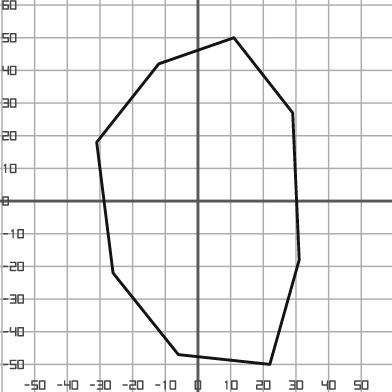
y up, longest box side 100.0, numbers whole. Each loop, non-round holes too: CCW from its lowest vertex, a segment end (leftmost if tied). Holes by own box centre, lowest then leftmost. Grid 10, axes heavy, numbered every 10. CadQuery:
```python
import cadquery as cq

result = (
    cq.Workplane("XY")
    .moveTo(22.0, -50.0)
    .lineTo(31.0, -18.0)
    .lineTo(29.0, 27.0)
    .lineTo(11.0, 50.0)
    .lineTo(-12.0, 42.0)
    .lineTo(-31.0, 18.0)
    .lineTo(-26.0, -22.0)
    .lineTo(-6.0, -47.0)
    .close()
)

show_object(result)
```